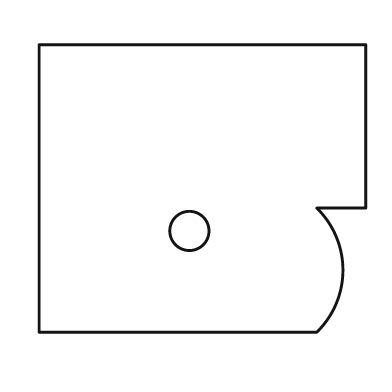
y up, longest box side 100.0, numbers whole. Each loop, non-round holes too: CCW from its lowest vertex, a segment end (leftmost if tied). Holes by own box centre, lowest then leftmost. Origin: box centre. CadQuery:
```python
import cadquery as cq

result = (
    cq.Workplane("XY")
    .moveTo(-50.0, -44.0)
    .lineTo(35.0, -44.0)
    .threePointArc((43.0, -25.0), (35.0, -6.0))
    .lineTo(50.0, -6.0)
    .lineTo(50.0, 44.0)
    .lineTo(-50.0, 44.0)
    .close()
    .moveTo(-4.0, -13.0)
    .circle(6.0)
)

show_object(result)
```